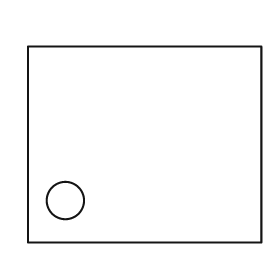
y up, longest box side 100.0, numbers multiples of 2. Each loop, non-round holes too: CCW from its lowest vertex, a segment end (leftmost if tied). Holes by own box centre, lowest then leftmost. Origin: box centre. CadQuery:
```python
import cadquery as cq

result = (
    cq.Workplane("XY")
    .moveTo(-50.0, -42.0)
    .lineTo(50.0, -42.0)
    .lineTo(50.0, 42.0)
    .lineTo(-50.0, 42.0)
    .close()
    .moveTo(-34.0, -24.0)
    .circle(8.0)
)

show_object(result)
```